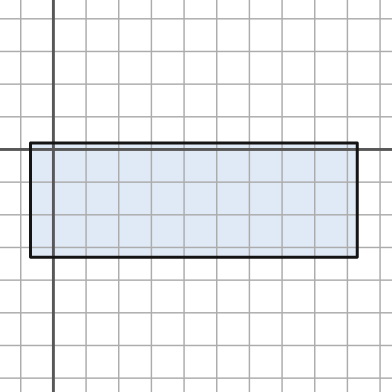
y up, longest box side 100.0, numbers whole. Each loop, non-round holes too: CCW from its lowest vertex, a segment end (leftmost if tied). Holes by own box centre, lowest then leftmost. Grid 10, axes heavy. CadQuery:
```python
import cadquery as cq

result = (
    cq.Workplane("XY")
    .moveTo(-7.0, -33.0)
    .lineTo(93.0, -33.0)
    .lineTo(93.0, 2.0)
    .lineTo(-7.0, 2.0)
    .close()
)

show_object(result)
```